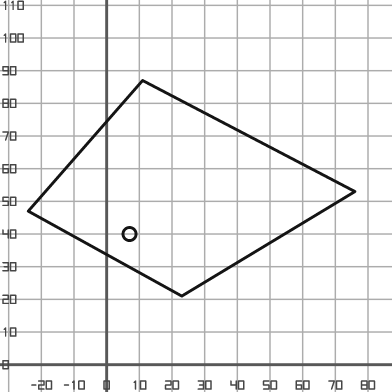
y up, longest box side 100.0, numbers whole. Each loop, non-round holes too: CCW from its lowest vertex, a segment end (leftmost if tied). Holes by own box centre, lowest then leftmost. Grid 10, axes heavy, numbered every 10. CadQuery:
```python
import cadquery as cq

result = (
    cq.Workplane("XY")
    .moveTo(23.0, 21.0)
    .lineTo(76.0, 53.0)
    .lineTo(11.0, 87.0)
    .lineTo(-24.0, 47.0)
    .close()
    .moveTo(7.0, 40.0)
    .circle(2.0)
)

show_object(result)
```